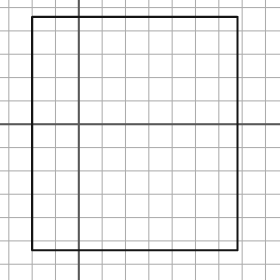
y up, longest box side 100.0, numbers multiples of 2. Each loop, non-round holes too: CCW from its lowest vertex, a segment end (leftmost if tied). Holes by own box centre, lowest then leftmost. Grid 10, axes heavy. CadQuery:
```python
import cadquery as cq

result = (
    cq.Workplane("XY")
    .moveTo(-20.0, -54.0)
    .lineTo(68.0, -54.0)
    .lineTo(68.0, 46.0)
    .lineTo(-20.0, 46.0)
    .close()
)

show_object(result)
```